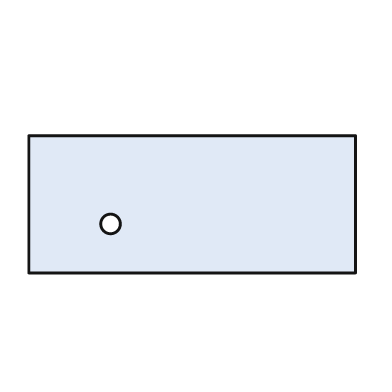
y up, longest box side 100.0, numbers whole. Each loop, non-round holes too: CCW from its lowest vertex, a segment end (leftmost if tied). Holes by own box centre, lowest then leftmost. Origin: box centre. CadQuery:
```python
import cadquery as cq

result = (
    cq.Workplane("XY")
    .moveTo(-50.0, -21.0)
    .lineTo(50.0, -21.0)
    .lineTo(50.0, 21.0)
    .lineTo(-50.0, 21.0)
    .close()
    .moveTo(-25.0, -6.0)
    .circle(3.0)
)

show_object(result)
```